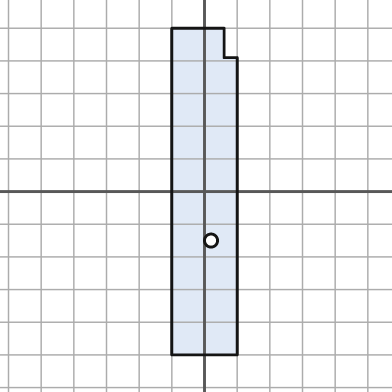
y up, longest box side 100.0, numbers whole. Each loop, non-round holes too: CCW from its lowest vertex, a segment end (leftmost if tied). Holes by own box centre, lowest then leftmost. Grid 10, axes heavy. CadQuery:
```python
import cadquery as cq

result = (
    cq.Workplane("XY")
    .moveTo(-10.0, -50.0)
    .lineTo(10.0, -50.0)
    .lineTo(10.0, 41.0)
    .lineTo(6.0, 41.0)
    .lineTo(6.0, 50.0)
    .lineTo(-10.0, 50.0)
    .close()
    .moveTo(2.0, -15.0)
    .circle(2.0)
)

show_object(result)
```